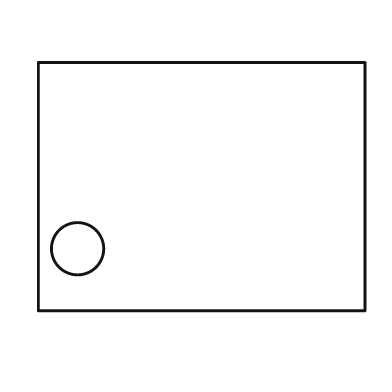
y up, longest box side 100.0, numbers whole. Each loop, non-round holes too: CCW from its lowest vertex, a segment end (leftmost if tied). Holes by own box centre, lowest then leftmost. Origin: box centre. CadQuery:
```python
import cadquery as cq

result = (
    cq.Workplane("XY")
    .moveTo(-50.0, -38.0)
    .lineTo(50.0, -38.0)
    .lineTo(50.0, 38.0)
    .lineTo(-50.0, 38.0)
    .close()
    .moveTo(-38.0, -19.0)
    .circle(8.0)
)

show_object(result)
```